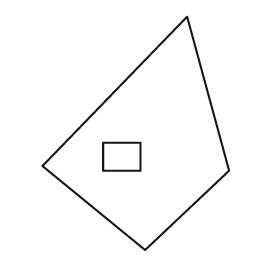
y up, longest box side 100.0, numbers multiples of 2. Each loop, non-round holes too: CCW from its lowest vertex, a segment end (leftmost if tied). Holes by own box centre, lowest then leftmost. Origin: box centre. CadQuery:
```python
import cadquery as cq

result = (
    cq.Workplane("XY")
    .moveTo(4.0, -50.0)
    .lineTo(40.0, -16.0)
    .lineTo(22.0, 50.0)
    .lineTo(-40.0, -14.0)
    .close()
    .moveTo(-14.0, -16.0)
    .lineTo(2.0, -16.0)
    .lineTo(2.0, -4.0)
    .lineTo(-14.0, -4.0)
    .close()
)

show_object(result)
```